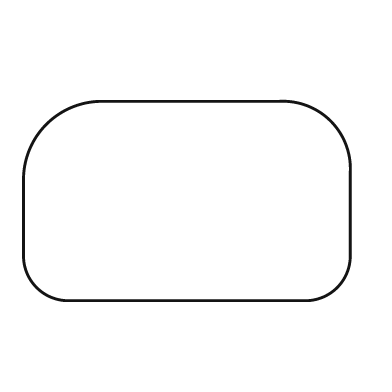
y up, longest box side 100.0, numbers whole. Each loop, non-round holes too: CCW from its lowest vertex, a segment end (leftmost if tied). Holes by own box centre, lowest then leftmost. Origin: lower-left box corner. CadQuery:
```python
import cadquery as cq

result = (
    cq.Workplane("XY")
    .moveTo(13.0, 0.0)
    .lineTo(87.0, 0.0)
    .threePointArc((96.0, 4.0), (100.0, 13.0))
    .lineTo(100.0, 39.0)
    .threePointArc((94.0, 55.0), (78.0, 61.0))
    .lineTo(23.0, 61.0)
    .threePointArc((7.0, 54.0), (0.0, 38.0))
    .lineTo(0.0, 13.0)
    .threePointArc((4.0, 4.0), (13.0, 0.0))
    .close()
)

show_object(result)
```